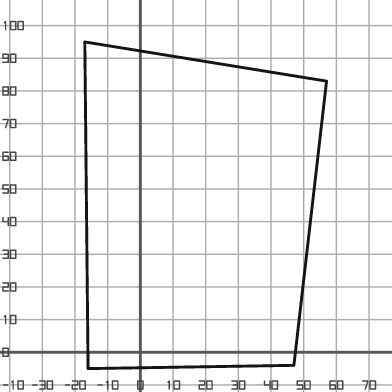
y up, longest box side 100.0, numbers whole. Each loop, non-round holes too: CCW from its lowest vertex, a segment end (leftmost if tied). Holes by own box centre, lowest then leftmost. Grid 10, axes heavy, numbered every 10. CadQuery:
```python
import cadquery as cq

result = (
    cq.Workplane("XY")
    .moveTo(-16.0, -5.0)
    .lineTo(47.0, -4.0)
    .lineTo(57.0, 83.0)
    .lineTo(-17.0, 95.0)
    .close()
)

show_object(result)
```